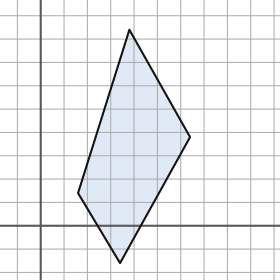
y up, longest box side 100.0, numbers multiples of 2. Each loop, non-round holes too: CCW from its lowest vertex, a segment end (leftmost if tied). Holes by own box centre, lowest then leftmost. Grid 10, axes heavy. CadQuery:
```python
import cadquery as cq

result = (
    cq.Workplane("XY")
    .moveTo(34.0, -16.0)
    .lineTo(64.0, 38.0)
    .lineTo(38.0, 84.0)
    .lineTo(16.0, 14.0)
    .close()
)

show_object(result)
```